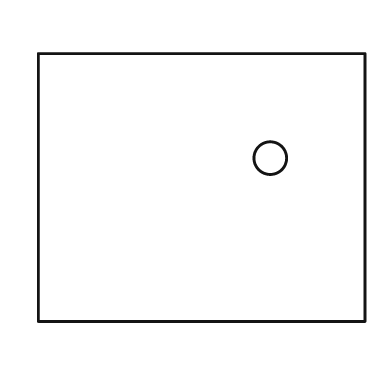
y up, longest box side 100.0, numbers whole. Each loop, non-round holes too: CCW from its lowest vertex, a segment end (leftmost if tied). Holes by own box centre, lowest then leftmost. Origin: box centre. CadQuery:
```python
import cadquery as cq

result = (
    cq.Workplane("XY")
    .moveTo(-50.0, -41.0)
    .lineTo(50.0, -41.0)
    .lineTo(50.0, 41.0)
    .lineTo(-50.0, 41.0)
    .close()
    .moveTo(21.0, 9.0)
    .circle(5.0)
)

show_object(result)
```